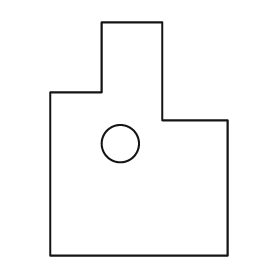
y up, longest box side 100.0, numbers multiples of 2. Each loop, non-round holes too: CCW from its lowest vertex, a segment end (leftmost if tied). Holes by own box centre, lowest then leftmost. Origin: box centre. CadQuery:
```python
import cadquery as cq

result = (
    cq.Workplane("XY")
    .moveTo(-38.0, -50.0)
    .lineTo(38.0, -50.0)
    .lineTo(38.0, 8.0)
    .lineTo(10.0, 8.0)
    .lineTo(10.0, 50.0)
    .lineTo(-16.0, 50.0)
    .lineTo(-16.0, 20.0)
    .lineTo(-38.0, 20.0)
    .close()
    .moveTo(-8.0, -2.0)
    .circle(8.0)
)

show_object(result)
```